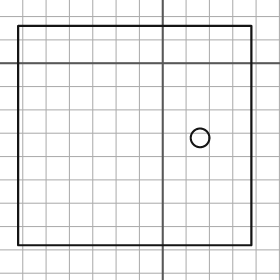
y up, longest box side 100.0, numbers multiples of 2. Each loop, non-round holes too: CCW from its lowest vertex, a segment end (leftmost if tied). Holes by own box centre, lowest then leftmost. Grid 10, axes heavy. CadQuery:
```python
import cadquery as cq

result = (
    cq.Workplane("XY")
    .moveTo(-62.0, -78.0)
    .lineTo(38.0, -78.0)
    .lineTo(38.0, 16.0)
    .lineTo(-62.0, 16.0)
    .close()
    .moveTo(16.0, -32.0)
    .circle(4.0)
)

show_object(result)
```